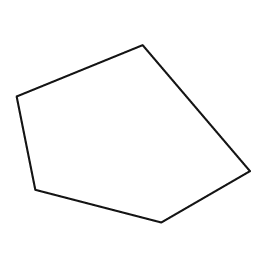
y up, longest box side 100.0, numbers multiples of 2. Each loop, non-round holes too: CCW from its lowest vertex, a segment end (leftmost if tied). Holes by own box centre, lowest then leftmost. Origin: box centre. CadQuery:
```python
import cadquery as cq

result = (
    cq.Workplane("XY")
    .moveTo(12.0, -38.0)
    .lineTo(50.0, -16.0)
    .lineTo(4.0, 38.0)
    .lineTo(-50.0, 16.0)
    .lineTo(-42.0, -24.0)
    .close()
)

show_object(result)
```